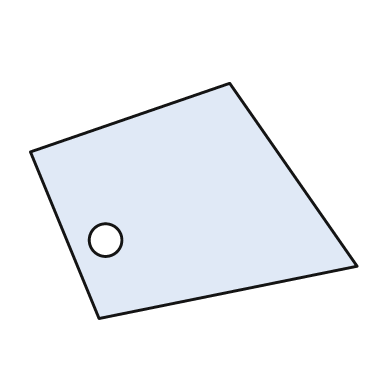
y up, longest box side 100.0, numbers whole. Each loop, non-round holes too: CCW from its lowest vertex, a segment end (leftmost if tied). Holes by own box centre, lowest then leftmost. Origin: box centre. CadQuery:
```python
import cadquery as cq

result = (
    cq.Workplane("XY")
    .moveTo(-29.0, -36.0)
    .lineTo(50.0, -20.0)
    .lineTo(11.0, 36.0)
    .lineTo(-50.0, 15.0)
    .close()
    .moveTo(-27.0, -12.0)
    .circle(5.0)
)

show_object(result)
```